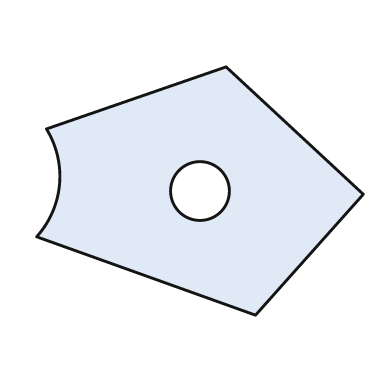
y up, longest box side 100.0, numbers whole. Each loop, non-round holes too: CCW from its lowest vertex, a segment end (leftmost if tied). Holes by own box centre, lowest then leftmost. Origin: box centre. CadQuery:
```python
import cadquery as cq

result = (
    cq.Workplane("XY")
    .moveTo(17.0, -38.0)
    .lineTo(50.0, -1.0)
    .lineTo(8.0, 38.0)
    .lineTo(-47.0, 19.0)
    .threePointArc((-43.0, 2.0), (-50.0, -14.0))
    .close()
    .moveTo(0.0, 0.0)
    .circle(9.0)
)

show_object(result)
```